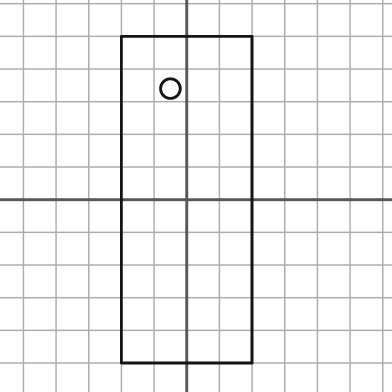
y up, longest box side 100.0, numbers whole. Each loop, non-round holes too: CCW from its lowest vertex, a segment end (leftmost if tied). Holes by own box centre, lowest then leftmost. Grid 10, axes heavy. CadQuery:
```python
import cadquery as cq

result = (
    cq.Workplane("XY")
    .moveTo(-20.0, -50.0)
    .lineTo(20.0, -50.0)
    .lineTo(20.0, 50.0)
    .lineTo(-20.0, 50.0)
    .close()
    .moveTo(-5.0, 34.0)
    .circle(3.0)
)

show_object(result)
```